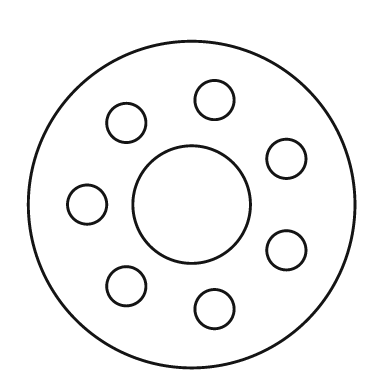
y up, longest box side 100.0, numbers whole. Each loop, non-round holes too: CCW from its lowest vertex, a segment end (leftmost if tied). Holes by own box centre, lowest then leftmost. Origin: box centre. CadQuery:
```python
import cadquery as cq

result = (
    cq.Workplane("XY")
    .moveTo(0.0, 0.0)
    .circle(50.0)
    .moveTo(7.0, -32.0)
    .circle(6.0)
    .moveTo(-20.0, -25.0)
    .circle(6.0)
    .moveTo(29.0, -14.0)
    .circle(6.0)
    .moveTo(-32.0, 0.0)
    .circle(6.0)
    .moveTo(0.0, 0.0)
    .circle(18.0)
    .moveTo(29.0, 14.0)
    .circle(6.0)
    .moveTo(-20.0, 25.0)
    .circle(6.0)
    .moveTo(7.0, 32.0)
    .circle(6.0)
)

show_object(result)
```